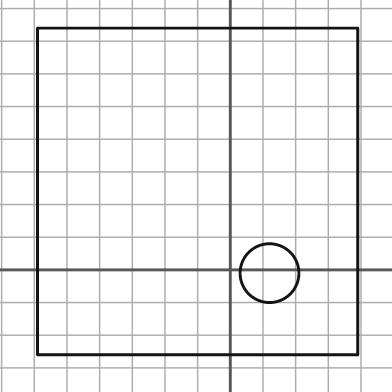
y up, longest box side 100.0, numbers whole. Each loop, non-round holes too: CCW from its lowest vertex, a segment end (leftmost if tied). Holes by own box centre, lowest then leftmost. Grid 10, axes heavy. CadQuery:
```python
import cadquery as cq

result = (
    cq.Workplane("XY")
    .moveTo(-59.0, -26.0)
    .lineTo(39.0, -26.0)
    .lineTo(39.0, 74.0)
    .lineTo(-59.0, 74.0)
    .close()
    .moveTo(12.0, -1.0)
    .circle(9.0)
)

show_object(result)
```